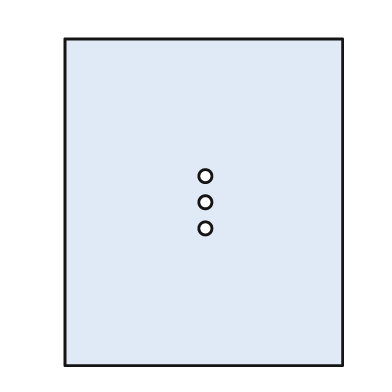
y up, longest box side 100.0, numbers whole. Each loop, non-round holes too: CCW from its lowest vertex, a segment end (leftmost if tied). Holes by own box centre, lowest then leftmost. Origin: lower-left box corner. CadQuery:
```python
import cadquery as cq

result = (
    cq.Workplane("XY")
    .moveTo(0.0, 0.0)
    .lineTo(85.0, 0.0)
    .lineTo(85.0, 100.0)
    .lineTo(0.0, 100.0)
    .close()
    .moveTo(43.0, 42.0)
    .circle(2.0)
    .moveTo(43.0, 50.0)
    .circle(2.0)
    .moveTo(43.0, 58.0)
    .circle(2.0)
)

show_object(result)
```